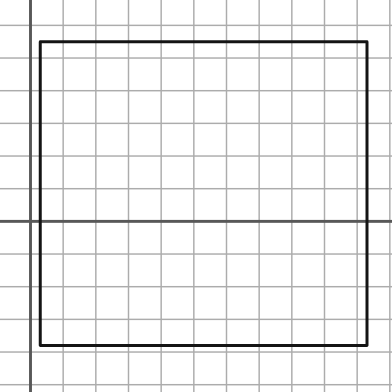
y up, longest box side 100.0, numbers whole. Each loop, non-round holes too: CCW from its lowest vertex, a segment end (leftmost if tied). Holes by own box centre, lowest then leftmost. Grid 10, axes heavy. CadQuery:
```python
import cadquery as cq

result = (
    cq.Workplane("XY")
    .moveTo(3.0, -38.0)
    .lineTo(103.0, -38.0)
    .lineTo(103.0, 55.0)
    .lineTo(3.0, 55.0)
    .close()
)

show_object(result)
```